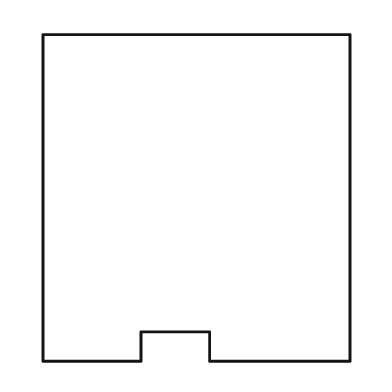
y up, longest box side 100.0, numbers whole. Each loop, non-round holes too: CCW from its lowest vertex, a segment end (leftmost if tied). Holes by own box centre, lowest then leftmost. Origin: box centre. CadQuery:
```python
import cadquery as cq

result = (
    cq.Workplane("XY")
    .moveTo(-47.0, -50.0)
    .lineTo(-17.0, -50.0)
    .lineTo(-17.0, -41.0)
    .lineTo(4.0, -41.0)
    .lineTo(4.0, -50.0)
    .lineTo(47.0, -50.0)
    .lineTo(47.0, 50.0)
    .lineTo(-47.0, 50.0)
    .close()
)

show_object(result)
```